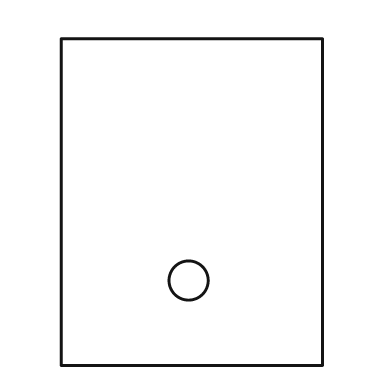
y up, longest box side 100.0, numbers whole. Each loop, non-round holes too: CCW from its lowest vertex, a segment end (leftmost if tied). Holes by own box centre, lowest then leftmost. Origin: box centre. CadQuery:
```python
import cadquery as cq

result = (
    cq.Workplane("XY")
    .moveTo(-40.0, -50.0)
    .lineTo(40.0, -50.0)
    .lineTo(40.0, 50.0)
    .lineTo(-40.0, 50.0)
    .close()
    .moveTo(-1.0, -24.0)
    .circle(6.0)
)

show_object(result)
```